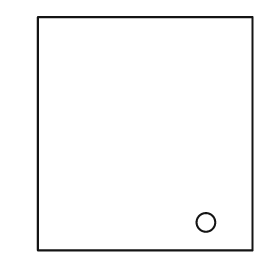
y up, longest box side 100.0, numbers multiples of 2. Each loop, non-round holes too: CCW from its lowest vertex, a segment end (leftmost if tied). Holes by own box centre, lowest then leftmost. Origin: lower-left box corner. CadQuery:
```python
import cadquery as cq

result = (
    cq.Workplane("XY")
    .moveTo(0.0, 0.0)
    .lineTo(92.0, 0.0)
    .lineTo(92.0, 100.0)
    .lineTo(0.0, 100.0)
    .close()
    .moveTo(72.0, 12.0)
    .circle(4.0)
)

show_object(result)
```